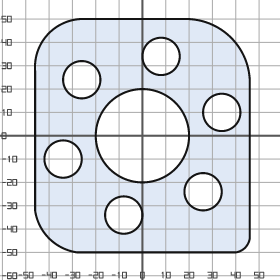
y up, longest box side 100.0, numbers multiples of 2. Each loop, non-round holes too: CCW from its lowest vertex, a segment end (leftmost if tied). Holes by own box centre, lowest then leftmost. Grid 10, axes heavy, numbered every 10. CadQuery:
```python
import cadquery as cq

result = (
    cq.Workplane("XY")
    .moveTo(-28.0, -50.0)
    .lineTo(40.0, -50.0)
    .threePointArc((44.0, -48.0), (46.0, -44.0))
    .lineTo(46.0, 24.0)
    .threePointArc((38.0, 42.0), (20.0, 50.0))
    .lineTo(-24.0, 50.0)
    .threePointArc((-40.0, 44.0), (-46.0, 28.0))
    .lineTo(-46.0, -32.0)
    .threePointArc((-40.0, -44.0), (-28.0, -50.0))
    .close()
    .moveTo(-8.0, -34.0)
    .circle(8.0)
    .moveTo(26.0, -24.0)
    .circle(8.0)
    .moveTo(-34.0, -10.0)
    .circle(8.0)
    .moveTo(0.0, 0.0)
    .circle(20.0)
    .moveTo(34.0, 10.0)
    .circle(8.0)
    .moveTo(-26.0, 24.0)
    .circle(8.0)
    .moveTo(8.0, 34.0)
    .circle(8.0)
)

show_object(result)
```